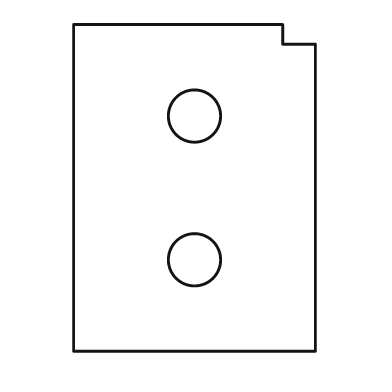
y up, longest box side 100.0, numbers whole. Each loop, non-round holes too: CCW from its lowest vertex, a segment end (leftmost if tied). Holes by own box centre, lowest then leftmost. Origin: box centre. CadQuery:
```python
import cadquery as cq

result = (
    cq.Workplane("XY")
    .moveTo(-37.0, -50.0)
    .lineTo(37.0, -50.0)
    .lineTo(37.0, 44.0)
    .lineTo(27.0, 44.0)
    .lineTo(27.0, 50.0)
    .lineTo(-37.0, 50.0)
    .close()
    .moveTo(0.0, -22.0)
    .circle(8.0)
    .moveTo(0.0, 22.0)
    .circle(8.0)
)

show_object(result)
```